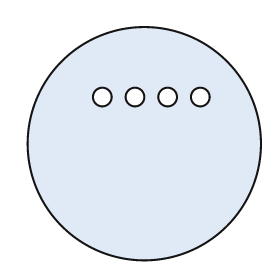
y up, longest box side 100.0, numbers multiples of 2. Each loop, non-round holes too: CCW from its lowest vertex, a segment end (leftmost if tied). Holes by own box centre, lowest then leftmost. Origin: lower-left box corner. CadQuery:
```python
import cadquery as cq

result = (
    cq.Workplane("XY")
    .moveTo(50.0, 50.0)
    .circle(50.0)
    .moveTo(32.0, 70.0)
    .circle(4.0)
    .moveTo(46.0, 70.0)
    .circle(4.0)
    .moveTo(60.0, 70.0)
    .circle(4.0)
    .moveTo(74.0, 70.0)
    .circle(4.0)
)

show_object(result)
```